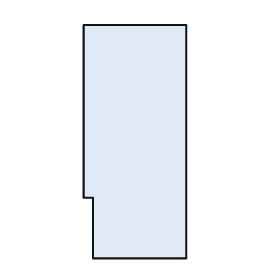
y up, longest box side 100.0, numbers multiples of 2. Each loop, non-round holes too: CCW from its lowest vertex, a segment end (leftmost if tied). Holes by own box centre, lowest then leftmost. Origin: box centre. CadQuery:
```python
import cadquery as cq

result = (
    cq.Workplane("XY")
    .moveTo(-18.0, -50.0)
    .lineTo(22.0, -50.0)
    .lineTo(22.0, 50.0)
    .lineTo(-22.0, 50.0)
    .lineTo(-22.0, -24.0)
    .lineTo(-18.0, -24.0)
    .close()
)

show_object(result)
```